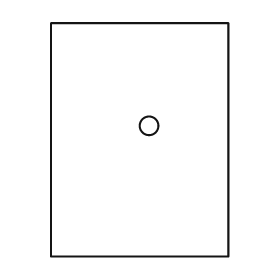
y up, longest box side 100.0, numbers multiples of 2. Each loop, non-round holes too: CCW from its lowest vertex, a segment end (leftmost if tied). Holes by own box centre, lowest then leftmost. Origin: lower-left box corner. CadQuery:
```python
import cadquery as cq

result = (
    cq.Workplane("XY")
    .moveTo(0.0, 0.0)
    .lineTo(76.0, 0.0)
    .lineTo(76.0, 100.0)
    .lineTo(0.0, 100.0)
    .close()
    .moveTo(42.0, 56.0)
    .circle(4.0)
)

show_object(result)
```